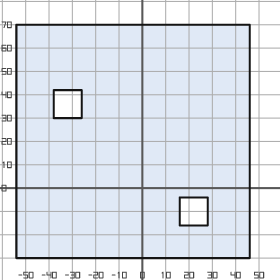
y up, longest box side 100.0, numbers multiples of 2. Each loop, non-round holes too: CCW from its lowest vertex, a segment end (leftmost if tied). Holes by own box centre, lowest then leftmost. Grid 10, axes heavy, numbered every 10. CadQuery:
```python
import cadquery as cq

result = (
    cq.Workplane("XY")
    .moveTo(-54.0, -30.0)
    .lineTo(46.0, -30.0)
    .lineTo(46.0, 70.0)
    .lineTo(-54.0, 70.0)
    .close()
    .moveTo(16.0, -16.0)
    .lineTo(28.0, -16.0)
    .lineTo(28.0, -4.0)
    .lineTo(16.0, -4.0)
    .close()
    .moveTo(-38.0, 30.0)
    .lineTo(-26.0, 30.0)
    .lineTo(-26.0, 42.0)
    .lineTo(-38.0, 42.0)
    .close()
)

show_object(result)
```